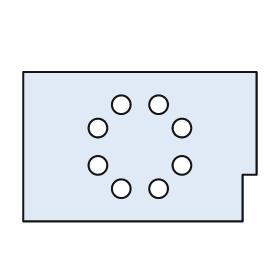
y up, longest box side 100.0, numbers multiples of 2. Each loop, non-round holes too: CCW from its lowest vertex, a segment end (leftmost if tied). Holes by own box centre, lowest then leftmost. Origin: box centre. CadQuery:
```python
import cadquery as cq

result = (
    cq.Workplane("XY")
    .moveTo(-50.0, -32.0)
    .lineTo(44.0, -32.0)
    .lineTo(44.0, -12.0)
    .lineTo(50.0, -12.0)
    .lineTo(50.0, 32.0)
    .lineTo(-50.0, 32.0)
    .close()
    .moveTo(-8.0, -18.0)
    .circle(4.0)
    .moveTo(8.0, -18.0)
    .circle(4.0)
    .moveTo(-18.0, -8.0)
    .circle(4.0)
    .moveTo(18.0, -8.0)
    .circle(4.0)
    .moveTo(-18.0, 8.0)
    .circle(4.0)
    .moveTo(18.0, 8.0)
    .circle(4.0)
    .moveTo(-8.0, 18.0)
    .circle(4.0)
    .moveTo(8.0, 18.0)
    .circle(4.0)
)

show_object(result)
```